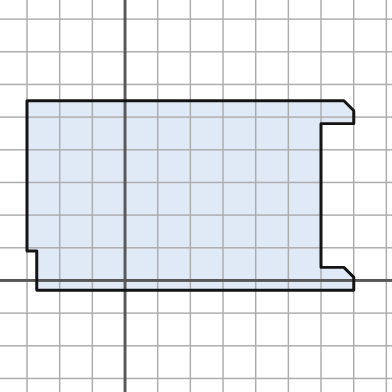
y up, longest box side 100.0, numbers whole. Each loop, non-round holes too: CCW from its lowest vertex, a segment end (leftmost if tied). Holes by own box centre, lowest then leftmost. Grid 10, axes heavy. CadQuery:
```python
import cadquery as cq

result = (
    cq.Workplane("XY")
    .moveTo(-27.0, -3.0)
    .lineTo(70.0, -3.0)
    .lineTo(70.0, 1.0)
    .lineTo(67.0, 4.0)
    .lineTo(60.0, 4.0)
    .lineTo(60.0, 48.0)
    .lineTo(70.0, 48.0)
    .lineTo(70.0, 52.0)
    .lineTo(67.0, 55.0)
    .lineTo(-30.0, 55.0)
    .lineTo(-30.0, 9.0)
    .lineTo(-27.0, 9.0)
    .close()
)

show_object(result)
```